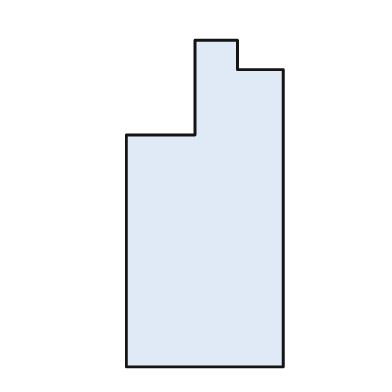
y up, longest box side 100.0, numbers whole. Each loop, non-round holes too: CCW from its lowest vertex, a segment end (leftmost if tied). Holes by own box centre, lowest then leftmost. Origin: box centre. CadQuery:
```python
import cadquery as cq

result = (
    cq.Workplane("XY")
    .moveTo(-24.0, -50.0)
    .lineTo(24.0, -50.0)
    .lineTo(24.0, 41.0)
    .lineTo(10.0, 41.0)
    .lineTo(10.0, 50.0)
    .lineTo(-3.0, 50.0)
    .lineTo(-3.0, 21.0)
    .lineTo(-24.0, 21.0)
    .close()
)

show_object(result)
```